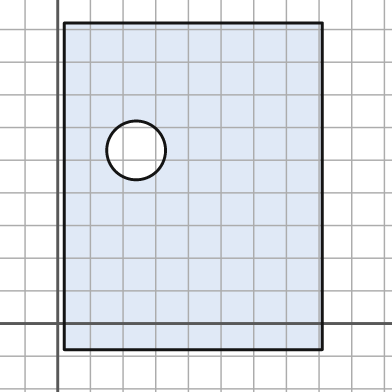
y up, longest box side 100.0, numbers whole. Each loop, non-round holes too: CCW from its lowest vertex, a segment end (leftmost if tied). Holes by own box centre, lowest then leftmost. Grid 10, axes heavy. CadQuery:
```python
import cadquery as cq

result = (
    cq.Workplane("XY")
    .moveTo(2.0, -8.0)
    .lineTo(81.0, -8.0)
    .lineTo(81.0, 92.0)
    .lineTo(2.0, 92.0)
    .close()
    .moveTo(24.0, 53.0)
    .circle(9.0)
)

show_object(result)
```